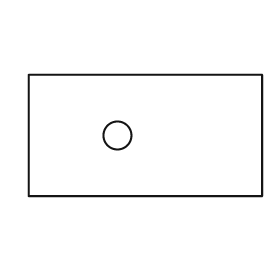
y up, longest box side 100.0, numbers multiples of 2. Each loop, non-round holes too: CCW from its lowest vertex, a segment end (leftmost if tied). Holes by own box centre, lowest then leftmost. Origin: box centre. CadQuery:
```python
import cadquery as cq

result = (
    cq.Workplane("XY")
    .moveTo(-50.0, -26.0)
    .lineTo(50.0, -26.0)
    .lineTo(50.0, 26.0)
    .lineTo(-50.0, 26.0)
    .close()
    .moveTo(-12.0, 0.0)
    .circle(6.0)
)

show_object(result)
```